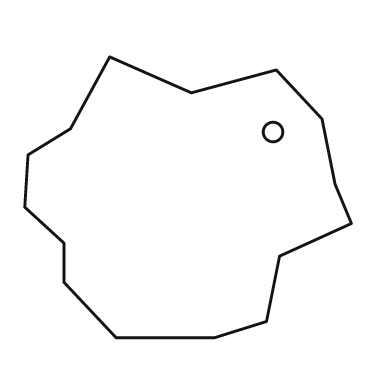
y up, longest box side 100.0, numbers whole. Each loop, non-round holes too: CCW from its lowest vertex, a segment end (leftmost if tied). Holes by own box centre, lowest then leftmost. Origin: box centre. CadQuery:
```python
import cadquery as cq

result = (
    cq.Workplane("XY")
    .moveTo(-22.0, -43.0)
    .lineTo(8.0, -43.0)
    .lineTo(24.0, -38.0)
    .lineTo(28.0, -18.0)
    .lineTo(50.0, -8.0)
    .lineTo(45.0, 4.0)
    .lineTo(41.0, 24.0)
    .lineTo(27.0, 39.0)
    .lineTo(1.0, 32.0)
    .lineTo(-24.0, 43.0)
    .lineTo(-36.0, 21.0)
    .lineTo(-49.0, 13.0)
    .lineTo(-50.0, -3.0)
    .lineTo(-38.0, -14.0)
    .lineTo(-38.0, -26.0)
    .close()
    .moveTo(26.0, 20.0)
    .circle(3.0)
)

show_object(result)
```